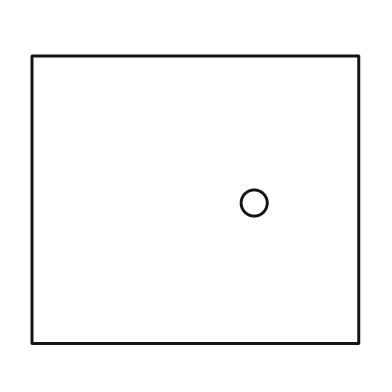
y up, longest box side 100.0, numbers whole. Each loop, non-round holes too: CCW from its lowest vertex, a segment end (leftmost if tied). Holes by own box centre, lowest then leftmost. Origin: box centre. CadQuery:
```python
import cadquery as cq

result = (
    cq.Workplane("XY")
    .moveTo(-50.0, -44.0)
    .lineTo(50.0, -44.0)
    .lineTo(50.0, 44.0)
    .lineTo(-50.0, 44.0)
    .close()
    .moveTo(18.0, -1.0)
    .circle(4.0)
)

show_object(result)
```